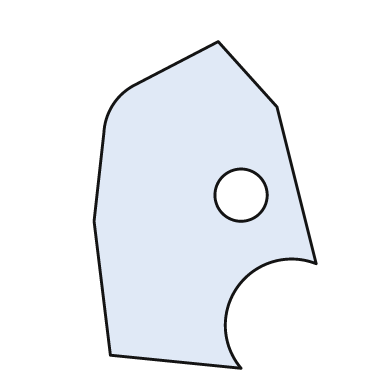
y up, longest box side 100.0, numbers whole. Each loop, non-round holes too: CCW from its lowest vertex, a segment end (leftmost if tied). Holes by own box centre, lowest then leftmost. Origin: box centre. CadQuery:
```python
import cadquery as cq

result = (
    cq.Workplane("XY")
    .moveTo(11.0, -50.0)
    .threePointArc((10.0, -25.0), (34.0, -18.0))
    .lineTo(22.0, 30.0)
    .lineTo(4.0, 50.0)
    .lineTo(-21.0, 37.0)
    .threePointArc((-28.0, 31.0), (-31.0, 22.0))
    .lineTo(-34.0, -5.0)
    .lineTo(-29.0, -46.0)
    .close()
    .moveTo(11.0, 3.0)
    .circle(8.0)
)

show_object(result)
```